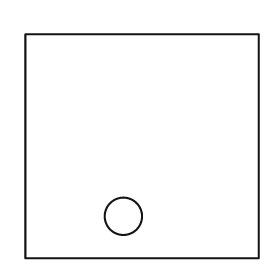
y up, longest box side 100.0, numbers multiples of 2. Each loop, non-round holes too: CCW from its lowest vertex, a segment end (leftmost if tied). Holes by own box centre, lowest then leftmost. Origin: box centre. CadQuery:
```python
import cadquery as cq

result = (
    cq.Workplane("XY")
    .moveTo(-50.0, -48.0)
    .lineTo(50.0, -48.0)
    .lineTo(50.0, 48.0)
    .lineTo(-50.0, 48.0)
    .close()
    .moveTo(-8.0, -30.0)
    .circle(8.0)
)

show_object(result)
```